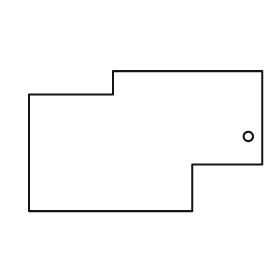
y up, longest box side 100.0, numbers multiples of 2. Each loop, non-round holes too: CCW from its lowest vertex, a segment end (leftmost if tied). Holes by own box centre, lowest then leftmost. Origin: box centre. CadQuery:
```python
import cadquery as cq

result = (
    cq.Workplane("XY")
    .moveTo(-50.0, -30.0)
    .lineTo(20.0, -30.0)
    .lineTo(20.0, -10.0)
    .lineTo(50.0, -10.0)
    .lineTo(50.0, 30.0)
    .lineTo(-14.0, 30.0)
    .lineTo(-14.0, 20.0)
    .lineTo(-50.0, 20.0)
    .close()
    .moveTo(44.0, 2.0)
    .circle(2.0)
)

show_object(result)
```